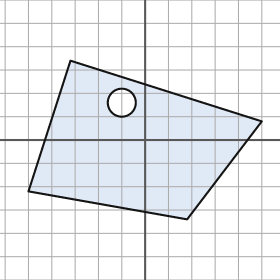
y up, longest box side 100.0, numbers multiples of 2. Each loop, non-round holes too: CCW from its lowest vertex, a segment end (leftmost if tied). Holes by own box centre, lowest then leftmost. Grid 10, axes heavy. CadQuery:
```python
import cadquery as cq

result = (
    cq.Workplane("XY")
    .moveTo(18.0, -34.0)
    .lineTo(50.0, 8.0)
    .lineTo(-32.0, 34.0)
    .lineTo(-50.0, -22.0)
    .close()
    .moveTo(-10.0, 16.0)
    .circle(6.0)
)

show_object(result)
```